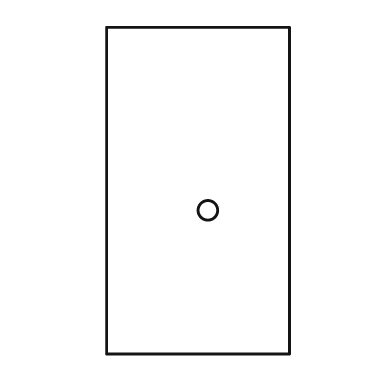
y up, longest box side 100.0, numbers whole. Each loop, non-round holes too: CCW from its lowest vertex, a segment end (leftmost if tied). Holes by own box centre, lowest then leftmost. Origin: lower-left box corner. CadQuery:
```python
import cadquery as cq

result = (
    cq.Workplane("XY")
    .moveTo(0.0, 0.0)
    .lineTo(56.0, 0.0)
    .lineTo(56.0, 100.0)
    .lineTo(0.0, 100.0)
    .close()
    .moveTo(31.0, 44.0)
    .circle(3.0)
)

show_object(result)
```